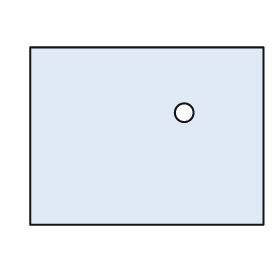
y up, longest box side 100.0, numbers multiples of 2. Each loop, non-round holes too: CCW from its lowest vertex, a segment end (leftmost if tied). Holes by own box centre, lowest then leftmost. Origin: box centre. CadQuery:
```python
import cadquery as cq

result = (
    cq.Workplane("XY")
    .moveTo(-50.0, -38.0)
    .lineTo(50.0, -38.0)
    .lineTo(50.0, 38.0)
    .lineTo(-50.0, 38.0)
    .close()
    .moveTo(16.0, 10.0)
    .circle(4.0)
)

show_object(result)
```